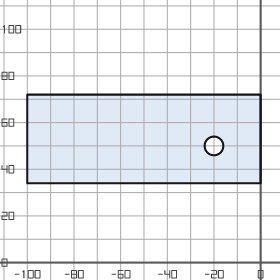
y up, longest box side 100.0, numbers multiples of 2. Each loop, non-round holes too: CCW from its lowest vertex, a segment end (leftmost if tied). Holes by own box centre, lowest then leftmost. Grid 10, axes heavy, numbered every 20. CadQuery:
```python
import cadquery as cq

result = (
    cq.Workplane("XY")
    .moveTo(-100.0, 34.0)
    .lineTo(0.0, 34.0)
    .lineTo(0.0, 72.0)
    .lineTo(-100.0, 72.0)
    .close()
    .moveTo(-20.0, 50.0)
    .circle(4.0)
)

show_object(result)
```